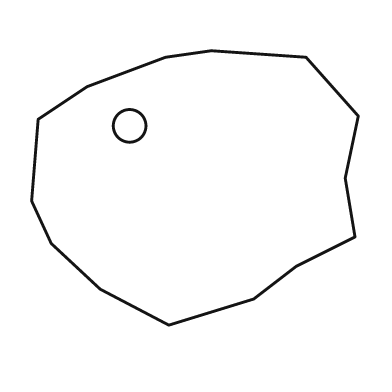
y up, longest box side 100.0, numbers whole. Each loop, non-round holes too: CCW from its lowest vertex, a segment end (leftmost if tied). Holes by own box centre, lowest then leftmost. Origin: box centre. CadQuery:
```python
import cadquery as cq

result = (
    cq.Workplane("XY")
    .moveTo(-8.0, -42.0)
    .lineTo(18.0, -34.0)
    .lineTo(31.0, -24.0)
    .lineTo(49.0, -15.0)
    .lineTo(46.0, 3.0)
    .lineTo(50.0, 22.0)
    .lineTo(34.0, 40.0)
    .lineTo(5.0, 42.0)
    .lineTo(-9.0, 40.0)
    .lineTo(-33.0, 31.0)
    .lineTo(-48.0, 21.0)
    .lineTo(-50.0, -4.0)
    .lineTo(-44.0, -17.0)
    .lineTo(-29.0, -31.0)
    .close()
    .moveTo(-20.0, 19.0)
    .circle(5.0)
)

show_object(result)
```